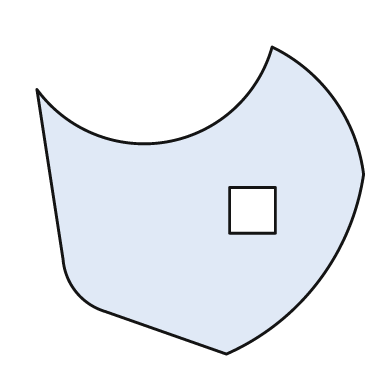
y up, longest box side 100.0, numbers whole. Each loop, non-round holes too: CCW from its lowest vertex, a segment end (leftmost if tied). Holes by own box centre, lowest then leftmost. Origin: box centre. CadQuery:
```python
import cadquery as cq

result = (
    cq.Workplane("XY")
    .moveTo(8.0, -47.0)
    .threePointArc((36.0, -25.0), (50.0, 8.0))
    .threePointArc((41.0, 31.0), (22.0, 47.0))
    .threePointArc((-10.0, 18.0), (-50.0, 34.0))
    .lineTo(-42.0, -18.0)
    .threePointArc((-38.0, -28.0), (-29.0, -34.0))
    .close()
    .moveTo(9.0, -10.0)
    .lineTo(23.0, -10.0)
    .lineTo(23.0, 4.0)
    .lineTo(9.0, 4.0)
    .close()
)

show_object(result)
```